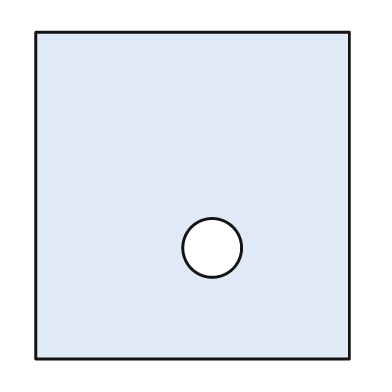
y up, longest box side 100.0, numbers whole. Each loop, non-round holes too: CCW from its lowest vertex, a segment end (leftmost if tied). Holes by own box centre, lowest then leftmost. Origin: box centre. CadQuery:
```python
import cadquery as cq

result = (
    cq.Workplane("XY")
    .moveTo(-48.0, -50.0)
    .lineTo(48.0, -50.0)
    .lineTo(48.0, 50.0)
    .lineTo(-48.0, 50.0)
    .close()
    .moveTo(6.0, -16.0)
    .circle(9.0)
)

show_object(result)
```